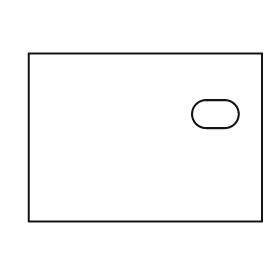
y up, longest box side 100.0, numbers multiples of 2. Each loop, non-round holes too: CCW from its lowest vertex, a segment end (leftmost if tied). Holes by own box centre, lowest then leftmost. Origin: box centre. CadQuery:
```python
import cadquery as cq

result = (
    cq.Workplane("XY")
    .moveTo(-50.0, -36.0)
    .lineTo(50.0, -36.0)
    .lineTo(50.0, 36.0)
    .lineTo(-50.0, 36.0)
    .close()
    .moveTo(26.0, 4.0)
    .lineTo(34.0, 4.0)
    .threePointArc((40.0, 10.0), (34.0, 16.0))
    .lineTo(26.0, 16.0)
    .threePointArc((20.0, 10.0), (26.0, 4.0))
    .close()
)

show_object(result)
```